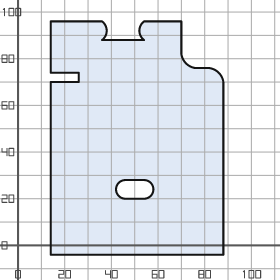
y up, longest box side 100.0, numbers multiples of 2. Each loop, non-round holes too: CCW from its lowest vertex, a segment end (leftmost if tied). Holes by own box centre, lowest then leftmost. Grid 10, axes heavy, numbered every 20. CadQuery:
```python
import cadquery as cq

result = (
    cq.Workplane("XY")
    .moveTo(14.0, -4.0)
    .lineTo(88.0, -4.0)
    .lineTo(88.0, 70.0)
    .threePointArc((86.0, 74.0), (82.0, 76.0))
    .lineTo(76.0, 76.0)
    .threePointArc((72.0, 78.0), (70.0, 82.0))
    .lineTo(70.0, 96.0)
    .lineTo(54.0, 96.0)
    .threePointArc((52.0, 92.0), (54.0, 88.0))
    .lineTo(36.0, 88.0)
    .threePointArc((38.0, 92.0), (36.0, 96.0))
    .lineTo(14.0, 96.0)
    .lineTo(14.0, 74.0)
    .lineTo(26.0, 74.0)
    .lineTo(26.0, 70.0)
    .lineTo(14.0, 70.0)
    .close()
    .moveTo(46.0, 20.0)
    .lineTo(54.0, 20.0)
    .threePointArc((58.0, 24.0), (54.0, 28.0))
    .lineTo(46.0, 28.0)
    .threePointArc((42.0, 24.0), (46.0, 20.0))
    .close()
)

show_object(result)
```